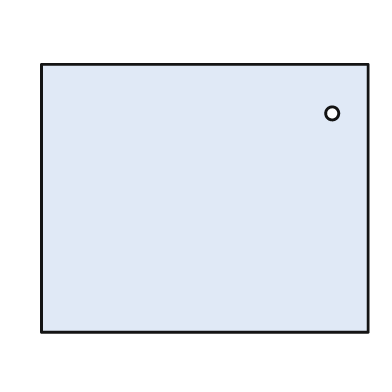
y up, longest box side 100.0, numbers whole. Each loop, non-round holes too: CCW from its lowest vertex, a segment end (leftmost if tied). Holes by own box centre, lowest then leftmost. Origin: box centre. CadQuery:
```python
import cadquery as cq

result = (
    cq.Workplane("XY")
    .moveTo(-50.0, -41.0)
    .lineTo(50.0, -41.0)
    .lineTo(50.0, 41.0)
    .lineTo(-50.0, 41.0)
    .close()
    .moveTo(39.0, 26.0)
    .circle(2.0)
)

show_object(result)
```